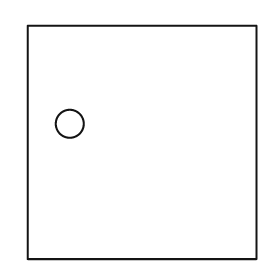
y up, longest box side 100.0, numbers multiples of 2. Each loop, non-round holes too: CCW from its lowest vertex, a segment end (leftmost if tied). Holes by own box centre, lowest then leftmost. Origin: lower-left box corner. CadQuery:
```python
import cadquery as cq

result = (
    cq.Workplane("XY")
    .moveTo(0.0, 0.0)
    .lineTo(98.0, 0.0)
    .lineTo(98.0, 100.0)
    .lineTo(0.0, 100.0)
    .close()
    .moveTo(18.0, 58.0)
    .circle(6.0)
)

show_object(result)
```